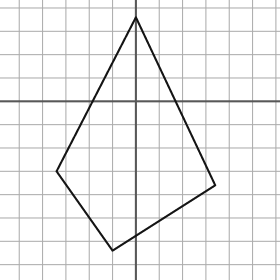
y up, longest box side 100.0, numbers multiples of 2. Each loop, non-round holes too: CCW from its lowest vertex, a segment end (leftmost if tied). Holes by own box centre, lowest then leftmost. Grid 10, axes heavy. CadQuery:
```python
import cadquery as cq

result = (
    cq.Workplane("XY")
    .moveTo(-10.0, -64.0)
    .lineTo(34.0, -36.0)
    .lineTo(0.0, 36.0)
    .lineTo(-34.0, -30.0)
    .close()
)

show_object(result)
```